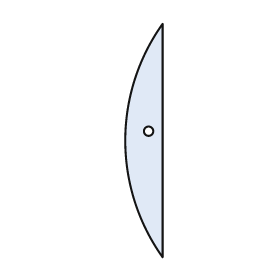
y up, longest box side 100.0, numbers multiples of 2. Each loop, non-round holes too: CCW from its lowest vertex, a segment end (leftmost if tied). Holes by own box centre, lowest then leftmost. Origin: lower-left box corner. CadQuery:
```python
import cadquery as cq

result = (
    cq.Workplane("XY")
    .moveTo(16.0, 0.0)
    .lineTo(16.0, 100.0)
    .threePointArc((0.0, 50.0), (16.0, 0.0))
    .close()
    .moveTo(10.0, 54.0)
    .circle(2.0)
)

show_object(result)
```